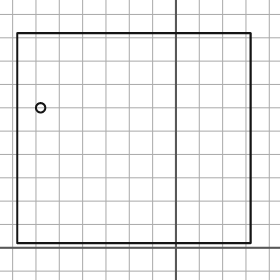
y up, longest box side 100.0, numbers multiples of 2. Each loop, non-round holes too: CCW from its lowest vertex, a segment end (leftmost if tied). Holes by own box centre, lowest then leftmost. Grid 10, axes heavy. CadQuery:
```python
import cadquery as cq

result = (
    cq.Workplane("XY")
    .moveTo(-68.0, 2.0)
    .lineTo(32.0, 2.0)
    .lineTo(32.0, 92.0)
    .lineTo(-68.0, 92.0)
    .close()
    .moveTo(-58.0, 60.0)
    .circle(2.0)
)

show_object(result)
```